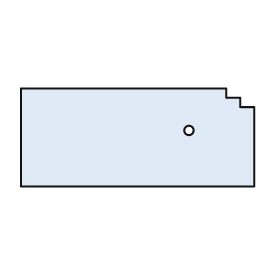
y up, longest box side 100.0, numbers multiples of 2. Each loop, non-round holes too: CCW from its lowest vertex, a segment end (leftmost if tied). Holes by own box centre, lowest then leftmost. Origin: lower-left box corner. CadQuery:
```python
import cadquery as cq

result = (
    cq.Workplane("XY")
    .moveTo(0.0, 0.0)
    .lineTo(100.0, 0.0)
    .lineTo(100.0, 34.0)
    .lineTo(94.0, 34.0)
    .lineTo(94.0, 38.0)
    .lineTo(88.0, 38.0)
    .lineTo(88.0, 42.0)
    .lineTo(0.0, 42.0)
    .close()
    .moveTo(72.0, 24.0)
    .circle(2.0)
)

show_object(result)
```